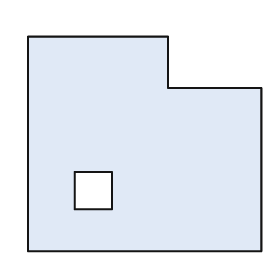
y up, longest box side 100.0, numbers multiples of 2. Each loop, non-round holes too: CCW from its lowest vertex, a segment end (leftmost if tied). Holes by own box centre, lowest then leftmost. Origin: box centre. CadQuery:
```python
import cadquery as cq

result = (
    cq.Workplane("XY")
    .moveTo(-50.0, -46.0)
    .lineTo(50.0, -46.0)
    .lineTo(50.0, 24.0)
    .lineTo(10.0, 24.0)
    .lineTo(10.0, 46.0)
    .lineTo(-50.0, 46.0)
    .close()
    .moveTo(-30.0, -28.0)
    .lineTo(-14.0, -28.0)
    .lineTo(-14.0, -12.0)
    .lineTo(-30.0, -12.0)
    .close()
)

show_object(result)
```